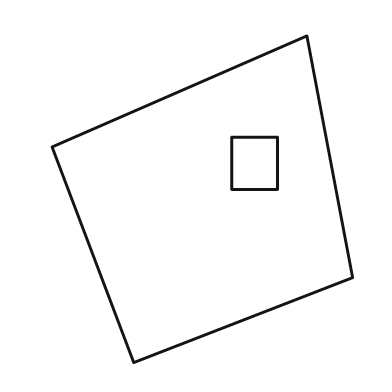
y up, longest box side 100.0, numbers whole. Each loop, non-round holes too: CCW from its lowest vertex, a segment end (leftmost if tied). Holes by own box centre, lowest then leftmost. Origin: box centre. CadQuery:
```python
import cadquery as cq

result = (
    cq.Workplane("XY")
    .moveTo(-21.0, -50.0)
    .lineTo(46.0, -24.0)
    .lineTo(32.0, 50.0)
    .lineTo(-46.0, 16.0)
    .close()
    .moveTo(9.0, 3.0)
    .lineTo(23.0, 3.0)
    .lineTo(23.0, 19.0)
    .lineTo(9.0, 19.0)
    .close()
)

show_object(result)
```